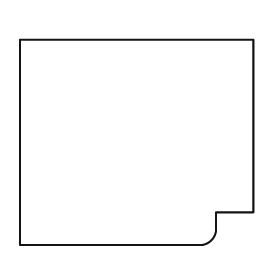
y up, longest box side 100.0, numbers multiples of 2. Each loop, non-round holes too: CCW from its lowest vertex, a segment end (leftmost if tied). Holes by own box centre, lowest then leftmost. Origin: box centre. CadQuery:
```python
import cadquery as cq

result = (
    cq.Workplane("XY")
    .moveTo(-50.0, -44.0)
    .lineTo(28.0, -44.0)
    .threePointArc((32.0, -42.0), (34.0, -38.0))
    .lineTo(34.0, -30.0)
    .lineTo(50.0, -30.0)
    .lineTo(50.0, 44.0)
    .lineTo(-50.0, 44.0)
    .close()
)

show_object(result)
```